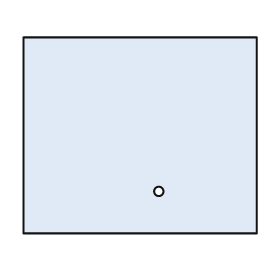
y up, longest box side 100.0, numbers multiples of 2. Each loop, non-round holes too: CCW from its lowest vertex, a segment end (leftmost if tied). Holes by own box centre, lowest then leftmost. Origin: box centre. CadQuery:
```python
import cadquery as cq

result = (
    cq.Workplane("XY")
    .moveTo(-50.0, -42.0)
    .lineTo(50.0, -42.0)
    .lineTo(50.0, 42.0)
    .lineTo(-50.0, 42.0)
    .close()
    .moveTo(8.0, -24.0)
    .circle(2.0)
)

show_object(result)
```